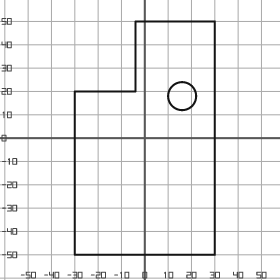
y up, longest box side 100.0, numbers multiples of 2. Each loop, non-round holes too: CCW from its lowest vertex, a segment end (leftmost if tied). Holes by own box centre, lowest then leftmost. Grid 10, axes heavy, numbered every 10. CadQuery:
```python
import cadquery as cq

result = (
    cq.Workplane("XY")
    .moveTo(-30.0, -50.0)
    .lineTo(30.0, -50.0)
    .lineTo(30.0, 50.0)
    .lineTo(-4.0, 50.0)
    .lineTo(-4.0, 20.0)
    .lineTo(-30.0, 20.0)
    .close()
    .moveTo(16.0, 18.0)
    .circle(6.0)
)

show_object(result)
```